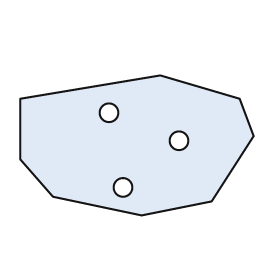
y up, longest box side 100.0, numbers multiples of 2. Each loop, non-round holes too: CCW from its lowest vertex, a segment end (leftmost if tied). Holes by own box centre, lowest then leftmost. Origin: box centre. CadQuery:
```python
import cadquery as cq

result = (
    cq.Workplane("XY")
    .moveTo(2.0, -30.0)
    .lineTo(32.0, -24.0)
    .lineTo(50.0, 4.0)
    .lineTo(44.0, 20.0)
    .lineTo(10.0, 30.0)
    .lineTo(-50.0, 20.0)
    .lineTo(-50.0, -6.0)
    .lineTo(-36.0, -22.0)
    .close()
    .moveTo(-6.0, -18.0)
    .circle(4.0)
    .moveTo(18.0, 2.0)
    .circle(4.0)
    .moveTo(-12.0, 14.0)
    .circle(4.0)
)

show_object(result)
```